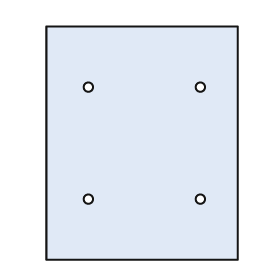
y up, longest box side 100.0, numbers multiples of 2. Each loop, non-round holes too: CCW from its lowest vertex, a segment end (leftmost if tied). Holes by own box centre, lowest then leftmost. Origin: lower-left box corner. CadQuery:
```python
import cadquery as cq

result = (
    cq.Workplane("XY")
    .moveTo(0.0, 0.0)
    .lineTo(82.0, 0.0)
    .lineTo(82.0, 100.0)
    .lineTo(0.0, 100.0)
    .close()
    .moveTo(18.0, 26.0)
    .circle(2.0)
    .moveTo(66.0, 26.0)
    .circle(2.0)
    .moveTo(18.0, 74.0)
    .circle(2.0)
    .moveTo(66.0, 74.0)
    .circle(2.0)
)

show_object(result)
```